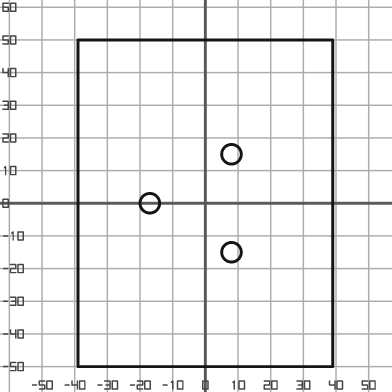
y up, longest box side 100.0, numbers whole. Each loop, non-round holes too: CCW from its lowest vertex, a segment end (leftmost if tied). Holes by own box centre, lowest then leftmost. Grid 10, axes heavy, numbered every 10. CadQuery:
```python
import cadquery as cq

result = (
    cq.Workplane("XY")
    .moveTo(-39.0, -50.0)
    .lineTo(39.0, -50.0)
    .lineTo(39.0, 50.0)
    .lineTo(-39.0, 50.0)
    .close()
    .moveTo(8.0, -15.0)
    .circle(3.0)
    .moveTo(-17.0, 0.0)
    .circle(3.0)
    .moveTo(8.0, 15.0)
    .circle(3.0)
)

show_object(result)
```